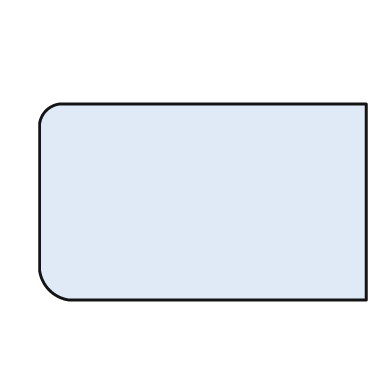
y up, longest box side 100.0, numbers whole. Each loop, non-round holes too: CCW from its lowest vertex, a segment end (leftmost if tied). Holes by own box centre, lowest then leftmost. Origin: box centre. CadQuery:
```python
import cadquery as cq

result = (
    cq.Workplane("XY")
    .moveTo(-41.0, -30.0)
    .lineTo(50.0, -30.0)
    .lineTo(50.0, 30.0)
    .lineTo(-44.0, 30.0)
    .threePointArc((-48.0, 28.0), (-50.0, 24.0))
    .lineTo(-50.0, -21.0)
    .threePointArc((-47.0, -27.0), (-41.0, -30.0))
    .close()
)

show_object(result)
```